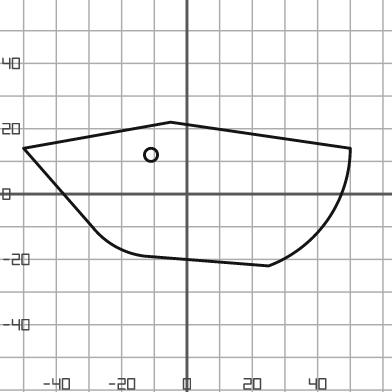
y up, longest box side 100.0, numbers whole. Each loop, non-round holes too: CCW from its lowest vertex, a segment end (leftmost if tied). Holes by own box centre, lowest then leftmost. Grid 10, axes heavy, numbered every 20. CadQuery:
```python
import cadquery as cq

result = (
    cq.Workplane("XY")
    .moveTo(25.0, -22.0)
    .threePointArc((43.0, -8.0), (50.0, 14.0))
    .lineTo(-5.0, 22.0)
    .lineTo(-50.0, 14.0)
    .lineTo(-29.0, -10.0)
    .threePointArc((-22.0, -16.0), (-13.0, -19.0))
    .close()
    .moveTo(-11.0, 12.0)
    .circle(2.0)
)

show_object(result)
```